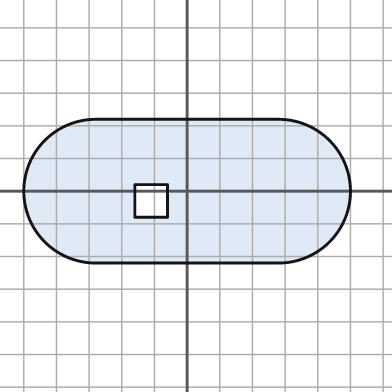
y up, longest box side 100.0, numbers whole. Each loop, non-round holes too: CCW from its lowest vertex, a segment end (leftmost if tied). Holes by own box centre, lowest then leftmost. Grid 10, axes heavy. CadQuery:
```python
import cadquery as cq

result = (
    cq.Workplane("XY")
    .moveTo(-28.0, -22.0)
    .lineTo(28.0, -22.0)
    .threePointArc((50.0, 0.0), (28.0, 22.0))
    .lineTo(-28.0, 22.0)
    .threePointArc((-50.0, 0.0), (-28.0, -22.0))
    .close()
    .moveTo(-16.0, -8.0)
    .lineTo(-6.0, -8.0)
    .lineTo(-6.0, 2.0)
    .lineTo(-16.0, 2.0)
    .close()
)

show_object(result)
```